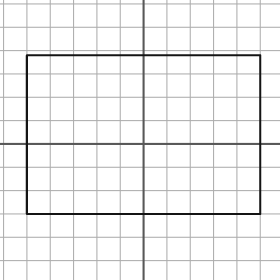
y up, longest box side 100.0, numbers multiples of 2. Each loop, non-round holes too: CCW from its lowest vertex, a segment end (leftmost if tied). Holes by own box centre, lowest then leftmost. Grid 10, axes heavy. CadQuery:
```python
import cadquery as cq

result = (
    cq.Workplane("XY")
    .moveTo(-50.0, -30.0)
    .lineTo(50.0, -30.0)
    .lineTo(50.0, 38.0)
    .lineTo(-50.0, 38.0)
    .close()
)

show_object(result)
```